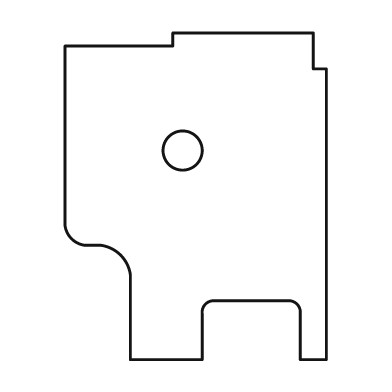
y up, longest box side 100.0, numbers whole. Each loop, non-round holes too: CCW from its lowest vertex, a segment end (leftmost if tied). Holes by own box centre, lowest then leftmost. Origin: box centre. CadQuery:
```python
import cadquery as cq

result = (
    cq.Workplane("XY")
    .moveTo(-20.0, -50.0)
    .lineTo(2.0, -50.0)
    .lineTo(2.0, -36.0)
    .threePointArc((3.0, -33.0), (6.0, -32.0))
    .lineTo(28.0, -32.0)
    .threePointArc((31.0, -33.0), (32.0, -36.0))
    .lineTo(32.0, -50.0)
    .lineTo(40.0, -50.0)
    .lineTo(40.0, 39.0)
    .lineTo(36.0, 39.0)
    .lineTo(36.0, 50.0)
    .lineTo(-7.0, 50.0)
    .lineTo(-7.0, 46.0)
    .lineTo(-40.0, 46.0)
    .lineTo(-40.0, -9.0)
    .threePointArc((-38.0, -13.0), (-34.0, -15.0))
    .lineTo(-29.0, -15.0)
    .threePointArc((-23.0, -18.0), (-20.0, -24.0))
    .close()
    .moveTo(-4.0, 14.0)
    .circle(6.0)
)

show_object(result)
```